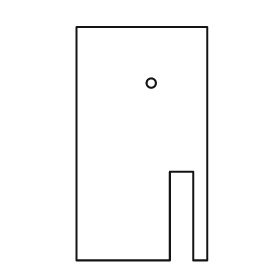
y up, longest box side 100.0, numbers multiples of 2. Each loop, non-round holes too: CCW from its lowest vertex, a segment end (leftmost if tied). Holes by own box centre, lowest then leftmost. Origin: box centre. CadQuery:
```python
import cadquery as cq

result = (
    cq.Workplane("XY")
    .moveTo(-28.0, -50.0)
    .lineTo(12.0, -50.0)
    .lineTo(12.0, -12.0)
    .lineTo(22.0, -12.0)
    .lineTo(22.0, -50.0)
    .lineTo(28.0, -50.0)
    .lineTo(28.0, 50.0)
    .lineTo(-28.0, 50.0)
    .close()
    .moveTo(4.0, 26.0)
    .circle(2.0)
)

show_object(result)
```